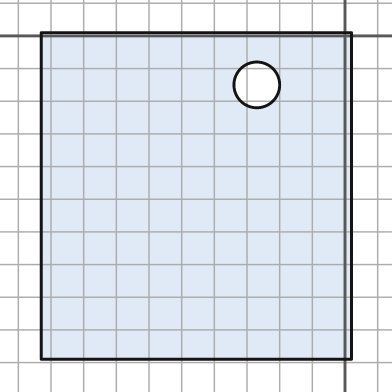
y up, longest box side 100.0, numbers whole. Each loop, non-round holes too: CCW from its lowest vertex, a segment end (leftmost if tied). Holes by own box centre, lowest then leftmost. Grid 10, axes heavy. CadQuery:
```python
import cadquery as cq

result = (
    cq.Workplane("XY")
    .moveTo(-93.0, -99.0)
    .lineTo(2.0, -99.0)
    .lineTo(2.0, 1.0)
    .lineTo(-93.0, 1.0)
    .close()
    .moveTo(-27.0, -15.0)
    .circle(7.0)
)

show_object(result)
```